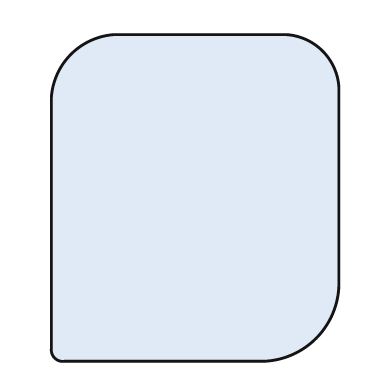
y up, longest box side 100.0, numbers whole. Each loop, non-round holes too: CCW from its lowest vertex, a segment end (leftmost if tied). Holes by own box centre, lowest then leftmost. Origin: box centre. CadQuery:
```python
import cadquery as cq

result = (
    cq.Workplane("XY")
    .moveTo(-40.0, -50.0)
    .lineTo(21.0, -50.0)
    .threePointArc((37.0, -43.0), (44.0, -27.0))
    .lineTo(44.0, 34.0)
    .threePointArc((39.0, 45.0), (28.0, 50.0))
    .lineTo(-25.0, 50.0)
    .threePointArc((-38.0, 44.0), (-44.0, 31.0))
    .lineTo(-44.0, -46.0)
    .threePointArc((-43.0, -49.0), (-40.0, -50.0))
    .close()
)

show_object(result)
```